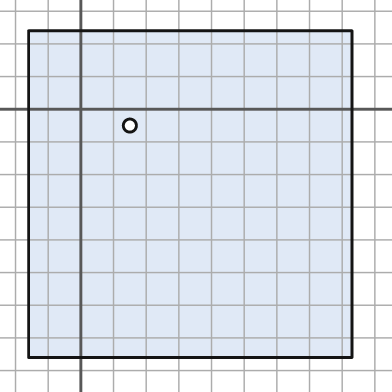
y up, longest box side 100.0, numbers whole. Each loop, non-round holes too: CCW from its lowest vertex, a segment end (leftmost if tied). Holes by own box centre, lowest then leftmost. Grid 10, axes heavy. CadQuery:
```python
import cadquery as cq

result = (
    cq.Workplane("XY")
    .moveTo(-16.0, -76.0)
    .lineTo(83.0, -76.0)
    .lineTo(83.0, 24.0)
    .lineTo(-16.0, 24.0)
    .close()
    .moveTo(15.0, -5.0)
    .circle(2.0)
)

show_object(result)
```